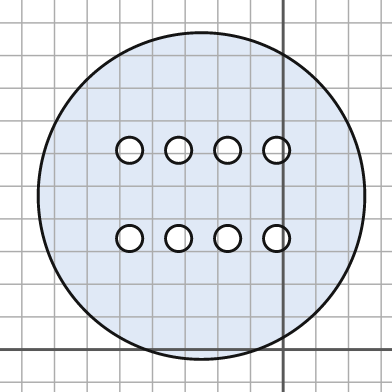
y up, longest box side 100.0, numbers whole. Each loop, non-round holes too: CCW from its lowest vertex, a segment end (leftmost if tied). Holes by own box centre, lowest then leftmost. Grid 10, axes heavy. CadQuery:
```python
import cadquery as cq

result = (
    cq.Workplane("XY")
    .moveTo(-25.0, 47.0)
    .circle(50.0)
    .moveTo(-47.0, 34.0)
    .circle(4.0)
    .moveTo(-32.0, 34.0)
    .circle(4.0)
    .moveTo(-17.0, 34.0)
    .circle(4.0)
    .moveTo(-2.0, 34.0)
    .circle(4.0)
    .moveTo(-47.0, 61.0)
    .circle(4.0)
    .moveTo(-32.0, 61.0)
    .circle(4.0)
    .moveTo(-17.0, 61.0)
    .circle(4.0)
    .moveTo(-2.0, 61.0)
    .circle(4.0)
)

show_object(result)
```